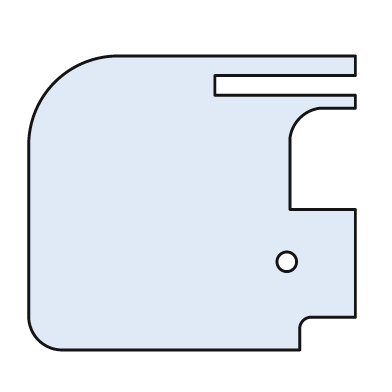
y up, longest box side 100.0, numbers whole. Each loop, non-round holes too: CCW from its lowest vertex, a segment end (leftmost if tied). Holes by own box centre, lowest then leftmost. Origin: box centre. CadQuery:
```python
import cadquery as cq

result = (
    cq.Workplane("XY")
    .moveTo(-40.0, -45.0)
    .lineTo(33.0, -45.0)
    .lineTo(33.0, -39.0)
    .threePointArc((34.0, -36.0), (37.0, -35.0))
    .lineTo(50.0, -35.0)
    .lineTo(50.0, -2.0)
    .lineTo(30.0, -2.0)
    .lineTo(30.0, 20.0)
    .threePointArc((33.0, 26.0), (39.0, 29.0))
    .lineTo(50.0, 29.0)
    .lineTo(50.0, 33.0)
    .lineTo(7.0, 33.0)
    .lineTo(7.0, 39.0)
    .lineTo(50.0, 39.0)
    .lineTo(50.0, 45.0)
    .lineTo(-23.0, 45.0)
    .threePointArc((-42.0, 37.0), (-50.0, 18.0))
    .lineTo(-50.0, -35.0)
    .threePointArc((-47.0, -42.0), (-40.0, -45.0))
    .close()
    .moveTo(29.0, -18.0)
    .circle(3.0)
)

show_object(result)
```